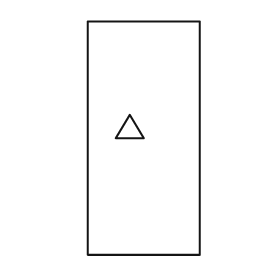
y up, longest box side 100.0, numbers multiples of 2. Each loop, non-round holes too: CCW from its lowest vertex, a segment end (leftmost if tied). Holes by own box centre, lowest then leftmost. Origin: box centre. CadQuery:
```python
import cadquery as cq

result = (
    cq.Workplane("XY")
    .moveTo(-24.0, -50.0)
    .lineTo(24.0, -50.0)
    .lineTo(24.0, 50.0)
    .lineTo(-24.0, 50.0)
    .close()
    .moveTo(-12.0, 0.0)
    .lineTo(0.0, 0.0)
    .lineTo(-6.0, 10.0)
    .close()
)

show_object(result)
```